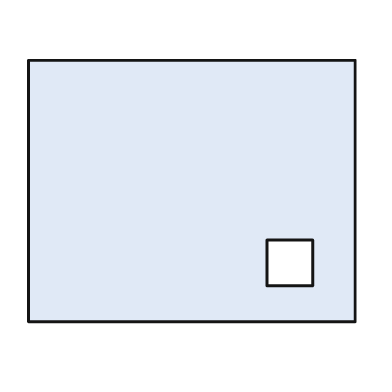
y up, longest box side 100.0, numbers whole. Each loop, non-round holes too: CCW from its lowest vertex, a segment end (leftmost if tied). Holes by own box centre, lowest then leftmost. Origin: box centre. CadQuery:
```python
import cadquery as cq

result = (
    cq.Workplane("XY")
    .moveTo(-50.0, -40.0)
    .lineTo(50.0, -40.0)
    .lineTo(50.0, 40.0)
    .lineTo(-50.0, 40.0)
    .close()
    .moveTo(23.0, -29.0)
    .lineTo(37.0, -29.0)
    .lineTo(37.0, -15.0)
    .lineTo(23.0, -15.0)
    .close()
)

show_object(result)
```